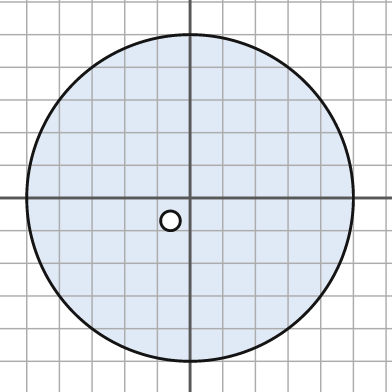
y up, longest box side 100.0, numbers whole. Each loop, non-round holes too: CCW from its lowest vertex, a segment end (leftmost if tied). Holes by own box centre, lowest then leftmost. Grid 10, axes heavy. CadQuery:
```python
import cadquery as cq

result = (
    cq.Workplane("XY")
    .moveTo(0.0, 0.0)
    .circle(50.0)
    .moveTo(-6.0, -7.0)
    .circle(3.0)
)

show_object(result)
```